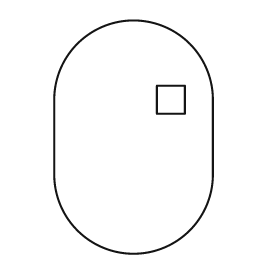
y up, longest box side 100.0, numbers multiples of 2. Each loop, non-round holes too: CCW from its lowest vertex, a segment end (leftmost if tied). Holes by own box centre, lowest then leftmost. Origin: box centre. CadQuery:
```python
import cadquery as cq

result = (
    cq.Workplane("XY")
    .moveTo(-34.0, -16.0)
    .threePointArc((0.0, -50.0), (34.0, -16.0))
    .lineTo(34.0, 16.0)
    .threePointArc((0.0, 50.0), (-34.0, 16.0))
    .close()
    .moveTo(10.0, 10.0)
    .lineTo(22.0, 10.0)
    .lineTo(22.0, 22.0)
    .lineTo(10.0, 22.0)
    .close()
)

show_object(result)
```